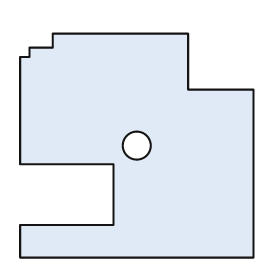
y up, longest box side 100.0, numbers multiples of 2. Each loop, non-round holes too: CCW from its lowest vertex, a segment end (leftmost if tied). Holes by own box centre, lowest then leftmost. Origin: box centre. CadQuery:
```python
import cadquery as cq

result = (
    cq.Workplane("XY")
    .moveTo(-50.0, -48.0)
    .lineTo(50.0, -48.0)
    .lineTo(50.0, 24.0)
    .lineTo(22.0, 24.0)
    .lineTo(22.0, 48.0)
    .lineTo(-36.0, 48.0)
    .lineTo(-36.0, 42.0)
    .lineTo(-46.0, 42.0)
    .lineTo(-46.0, 38.0)
    .lineTo(-50.0, 38.0)
    .lineTo(-50.0, -8.0)
    .lineTo(-10.0, -8.0)
    .lineTo(-10.0, -34.0)
    .lineTo(-50.0, -34.0)
    .close()
    .moveTo(0.0, 0.0)
    .circle(6.0)
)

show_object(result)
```